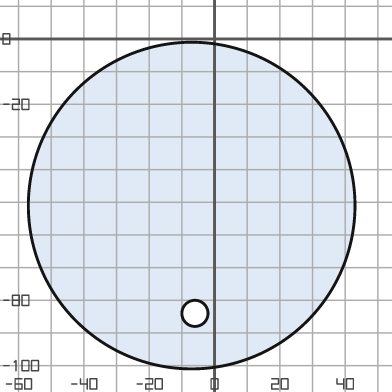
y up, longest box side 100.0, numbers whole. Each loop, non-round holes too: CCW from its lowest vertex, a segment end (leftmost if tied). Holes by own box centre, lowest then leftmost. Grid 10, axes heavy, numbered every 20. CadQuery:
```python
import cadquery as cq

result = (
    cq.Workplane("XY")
    .moveTo(-7.0, -51.0)
    .circle(50.0)
    .moveTo(-6.0, -84.0)
    .circle(4.0)
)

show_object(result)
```